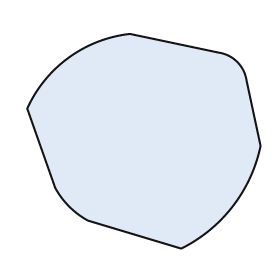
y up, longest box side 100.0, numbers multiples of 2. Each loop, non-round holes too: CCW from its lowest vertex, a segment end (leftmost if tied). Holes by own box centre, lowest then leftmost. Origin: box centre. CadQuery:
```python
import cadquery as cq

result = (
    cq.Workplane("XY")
    .moveTo(16.0, -46.0)
    .threePointArc((38.0, -28.0), (50.0, -2.0))
    .lineTo(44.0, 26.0)
    .threePointArc((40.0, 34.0), (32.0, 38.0))
    .lineTo(-6.0, 46.0)
    .threePointArc((-32.0, 36.0), (-50.0, 14.0))
    .lineTo(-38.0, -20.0)
    .threePointArc((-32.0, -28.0), (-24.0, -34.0))
    .close()
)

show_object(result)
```